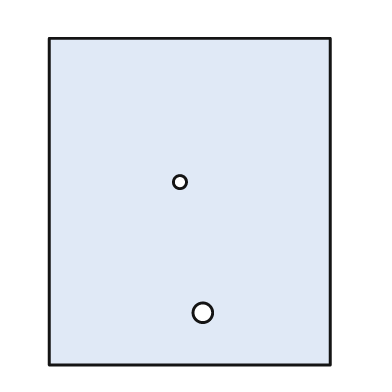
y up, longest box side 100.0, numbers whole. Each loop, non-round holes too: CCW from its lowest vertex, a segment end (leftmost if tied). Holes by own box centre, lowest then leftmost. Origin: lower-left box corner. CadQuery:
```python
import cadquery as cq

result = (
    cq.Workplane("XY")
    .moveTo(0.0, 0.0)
    .lineTo(86.0, 0.0)
    .lineTo(86.0, 100.0)
    .lineTo(0.0, 100.0)
    .close()
    .moveTo(47.0, 16.0)
    .circle(3.0)
    .moveTo(40.0, 56.0)
    .circle(2.0)
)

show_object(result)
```